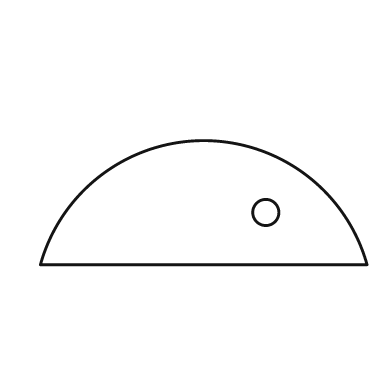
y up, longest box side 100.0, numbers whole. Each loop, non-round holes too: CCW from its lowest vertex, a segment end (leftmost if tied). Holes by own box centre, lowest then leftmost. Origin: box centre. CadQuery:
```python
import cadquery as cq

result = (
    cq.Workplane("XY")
    .moveTo(-50.0, -19.0)
    .lineTo(50.0, -19.0)
    .threePointArc((0.0, 19.0), (-50.0, -19.0))
    .close()
    .moveTo(19.0, -3.0)
    .circle(4.0)
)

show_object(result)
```